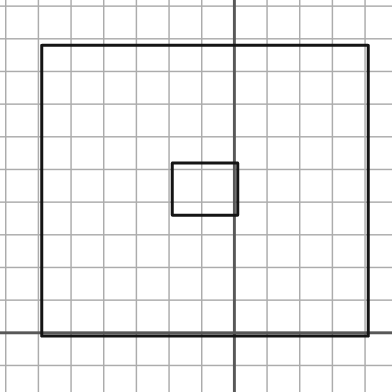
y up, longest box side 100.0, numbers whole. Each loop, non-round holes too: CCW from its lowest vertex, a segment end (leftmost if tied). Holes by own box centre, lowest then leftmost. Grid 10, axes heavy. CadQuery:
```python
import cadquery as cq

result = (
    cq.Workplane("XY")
    .moveTo(-59.0, -1.0)
    .lineTo(41.0, -1.0)
    .lineTo(41.0, 88.0)
    .lineTo(-59.0, 88.0)
    .close()
    .moveTo(-19.0, 36.0)
    .lineTo(1.0, 36.0)
    .lineTo(1.0, 52.0)
    .lineTo(-19.0, 52.0)
    .close()
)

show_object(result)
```